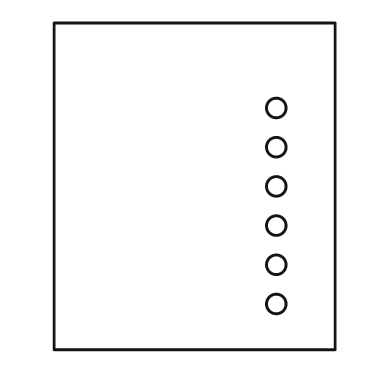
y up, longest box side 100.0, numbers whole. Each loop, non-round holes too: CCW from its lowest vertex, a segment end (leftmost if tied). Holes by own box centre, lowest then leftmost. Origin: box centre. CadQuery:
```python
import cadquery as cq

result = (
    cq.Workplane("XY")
    .moveTo(-43.0, -50.0)
    .lineTo(43.0, -50.0)
    .lineTo(43.0, 50.0)
    .lineTo(-43.0, 50.0)
    .close()
    .moveTo(25.0, -36.0)
    .circle(3.0)
    .moveTo(25.0, -24.0)
    .circle(3.0)
    .moveTo(25.0, -12.0)
    .circle(3.0)
    .moveTo(25.0, 0.0)
    .circle(3.0)
    .moveTo(25.0, 12.0)
    .circle(3.0)
    .moveTo(25.0, 24.0)
    .circle(3.0)
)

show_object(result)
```